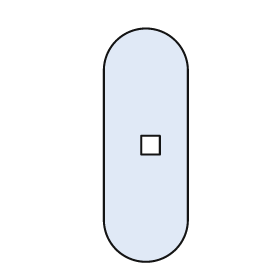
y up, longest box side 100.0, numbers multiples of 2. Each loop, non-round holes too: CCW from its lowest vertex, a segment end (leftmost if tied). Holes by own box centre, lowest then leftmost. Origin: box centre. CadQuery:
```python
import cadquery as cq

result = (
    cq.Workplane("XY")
    .moveTo(-18.0, -32.0)
    .threePointArc((0.0, -50.0), (18.0, -32.0))
    .lineTo(18.0, 32.0)
    .threePointArc((0.0, 50.0), (-18.0, 32.0))
    .close()
    .moveTo(-2.0, -4.0)
    .lineTo(6.0, -4.0)
    .lineTo(6.0, 4.0)
    .lineTo(-2.0, 4.0)
    .close()
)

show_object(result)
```